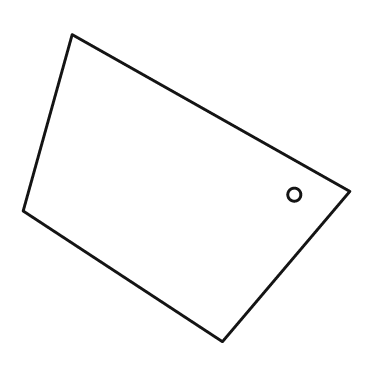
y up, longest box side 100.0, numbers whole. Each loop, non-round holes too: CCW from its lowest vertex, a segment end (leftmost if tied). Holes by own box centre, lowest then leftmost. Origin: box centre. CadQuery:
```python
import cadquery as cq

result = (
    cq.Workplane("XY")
    .moveTo(11.0, -47.0)
    .lineTo(50.0, -1.0)
    .lineTo(-35.0, 47.0)
    .lineTo(-50.0, -7.0)
    .close()
    .moveTo(33.0, -2.0)
    .circle(2.0)
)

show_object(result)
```